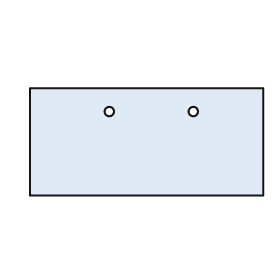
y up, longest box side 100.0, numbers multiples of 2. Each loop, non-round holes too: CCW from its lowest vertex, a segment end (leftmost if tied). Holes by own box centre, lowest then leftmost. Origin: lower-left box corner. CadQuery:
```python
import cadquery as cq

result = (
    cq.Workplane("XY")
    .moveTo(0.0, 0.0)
    .lineTo(100.0, 0.0)
    .lineTo(100.0, 46.0)
    .lineTo(0.0, 46.0)
    .close()
    .moveTo(34.0, 36.0)
    .circle(2.0)
    .moveTo(70.0, 36.0)
    .circle(2.0)
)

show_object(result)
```